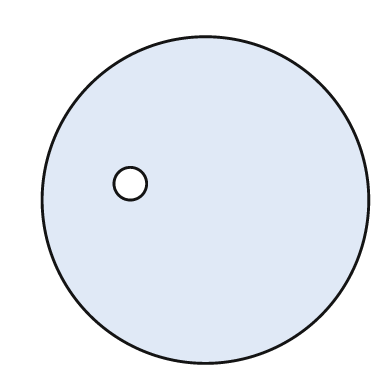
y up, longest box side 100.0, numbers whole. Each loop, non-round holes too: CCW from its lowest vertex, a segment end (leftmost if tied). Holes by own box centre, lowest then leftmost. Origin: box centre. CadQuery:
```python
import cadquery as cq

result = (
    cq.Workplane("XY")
    .moveTo(0.0, 0.0)
    .circle(50.0)
    .moveTo(-23.0, 5.0)
    .circle(5.0)
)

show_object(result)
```